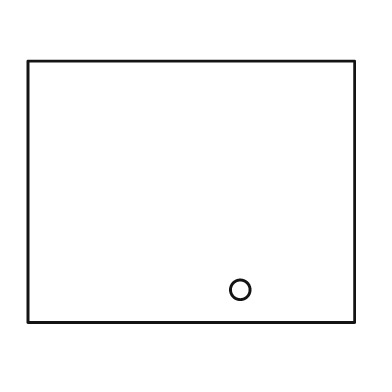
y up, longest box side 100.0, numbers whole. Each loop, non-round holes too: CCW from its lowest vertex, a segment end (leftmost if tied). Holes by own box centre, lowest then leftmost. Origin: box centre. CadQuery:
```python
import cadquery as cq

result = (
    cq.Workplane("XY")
    .moveTo(-50.0, -40.0)
    .lineTo(50.0, -40.0)
    .lineTo(50.0, 40.0)
    .lineTo(-50.0, 40.0)
    .close()
    .moveTo(15.0, -30.0)
    .circle(3.0)
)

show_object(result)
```